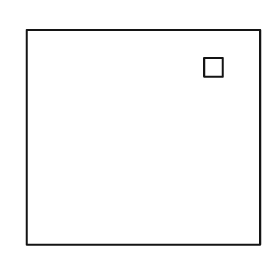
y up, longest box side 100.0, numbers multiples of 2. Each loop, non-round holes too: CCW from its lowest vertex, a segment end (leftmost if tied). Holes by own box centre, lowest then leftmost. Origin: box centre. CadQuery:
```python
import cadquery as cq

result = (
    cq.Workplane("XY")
    .moveTo(-50.0, -46.0)
    .lineTo(50.0, -46.0)
    .lineTo(50.0, 46.0)
    .lineTo(-50.0, 46.0)
    .close()
    .moveTo(26.0, 26.0)
    .lineTo(34.0, 26.0)
    .lineTo(34.0, 34.0)
    .lineTo(26.0, 34.0)
    .close()
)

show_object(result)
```